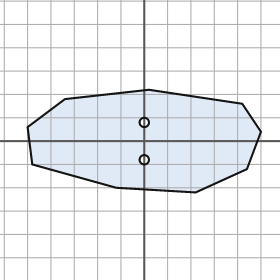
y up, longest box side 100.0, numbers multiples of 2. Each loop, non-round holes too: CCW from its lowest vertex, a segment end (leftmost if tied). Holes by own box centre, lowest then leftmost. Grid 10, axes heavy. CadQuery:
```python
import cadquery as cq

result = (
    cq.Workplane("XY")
    .moveTo(22.0, -22.0)
    .lineTo(44.0, -12.0)
    .lineTo(50.0, 4.0)
    .lineTo(42.0, 16.0)
    .lineTo(2.0, 22.0)
    .lineTo(-34.0, 18.0)
    .lineTo(-50.0, 6.0)
    .lineTo(-48.0, -10.0)
    .lineTo(-12.0, -20.0)
    .close()
    .moveTo(0.0, -8.0)
    .circle(2.0)
    .moveTo(0.0, 8.0)
    .circle(2.0)
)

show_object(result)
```